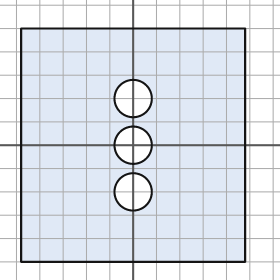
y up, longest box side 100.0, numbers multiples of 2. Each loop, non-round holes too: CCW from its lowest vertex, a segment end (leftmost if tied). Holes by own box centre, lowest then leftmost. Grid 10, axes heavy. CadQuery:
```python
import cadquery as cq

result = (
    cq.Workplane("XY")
    .moveTo(-48.0, -50.0)
    .lineTo(48.0, -50.0)
    .lineTo(48.0, 50.0)
    .lineTo(-48.0, 50.0)
    .close()
    .moveTo(0.0, -20.0)
    .circle(8.0)
    .moveTo(0.0, 0.0)
    .circle(8.0)
    .moveTo(0.0, 20.0)
    .circle(8.0)
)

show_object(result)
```